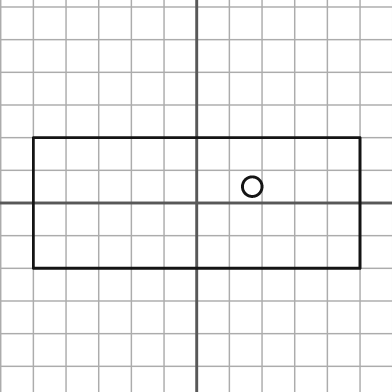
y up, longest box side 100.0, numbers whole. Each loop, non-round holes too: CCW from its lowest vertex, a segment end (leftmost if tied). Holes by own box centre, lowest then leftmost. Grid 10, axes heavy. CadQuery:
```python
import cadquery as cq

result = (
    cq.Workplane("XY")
    .moveTo(-50.0, -20.0)
    .lineTo(50.0, -20.0)
    .lineTo(50.0, 20.0)
    .lineTo(-50.0, 20.0)
    .close()
    .moveTo(17.0, 5.0)
    .circle(3.0)
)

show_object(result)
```